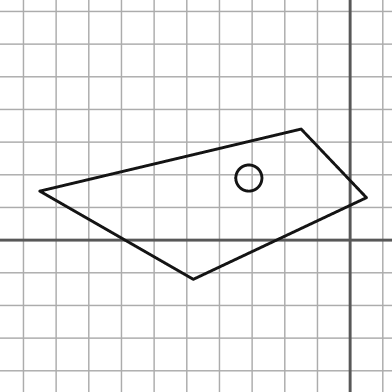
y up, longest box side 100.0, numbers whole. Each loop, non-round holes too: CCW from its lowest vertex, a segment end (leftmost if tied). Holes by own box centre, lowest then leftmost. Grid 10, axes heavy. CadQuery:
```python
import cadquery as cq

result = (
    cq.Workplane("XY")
    .moveTo(-48.0, -12.0)
    .lineTo(5.0, 13.0)
    .lineTo(-15.0, 34.0)
    .lineTo(-95.0, 15.0)
    .close()
    .moveTo(-31.0, 19.0)
    .circle(4.0)
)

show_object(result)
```